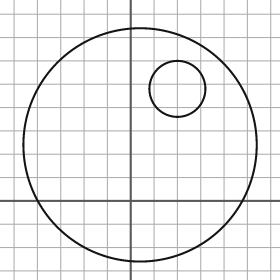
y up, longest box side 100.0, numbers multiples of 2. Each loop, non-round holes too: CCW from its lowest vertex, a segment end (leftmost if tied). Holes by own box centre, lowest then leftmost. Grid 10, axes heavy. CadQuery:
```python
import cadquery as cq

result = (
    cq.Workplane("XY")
    .moveTo(4.0, 24.0)
    .circle(50.0)
    .moveTo(20.0, 48.0)
    .circle(12.0)
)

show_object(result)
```